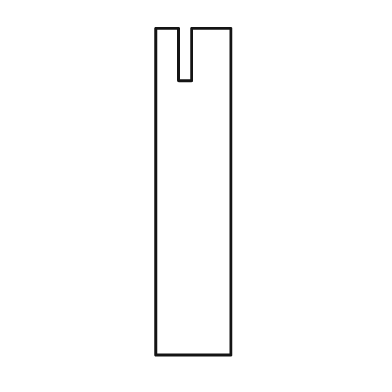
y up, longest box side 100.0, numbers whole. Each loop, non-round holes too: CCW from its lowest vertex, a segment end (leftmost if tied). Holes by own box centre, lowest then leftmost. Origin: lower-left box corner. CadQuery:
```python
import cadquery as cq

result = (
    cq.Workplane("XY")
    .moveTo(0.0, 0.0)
    .lineTo(23.0, 0.0)
    .lineTo(23.0, 100.0)
    .lineTo(11.0, 100.0)
    .lineTo(11.0, 84.0)
    .lineTo(7.0, 84.0)
    .lineTo(7.0, 100.0)
    .lineTo(0.0, 100.0)
    .close()
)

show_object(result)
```